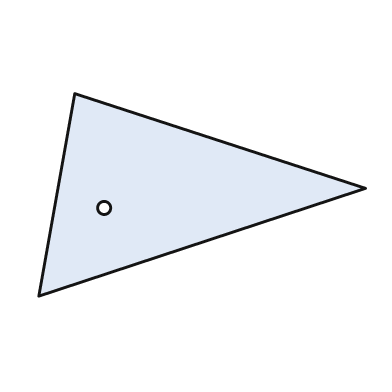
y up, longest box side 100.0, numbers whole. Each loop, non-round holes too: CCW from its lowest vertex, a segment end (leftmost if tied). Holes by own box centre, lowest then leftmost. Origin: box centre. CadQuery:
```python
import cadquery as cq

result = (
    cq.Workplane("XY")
    .moveTo(-50.0, -31.0)
    .lineTo(50.0, 2.0)
    .lineTo(-39.0, 31.0)
    .close()
    .moveTo(-30.0, -4.0)
    .circle(2.0)
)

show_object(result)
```